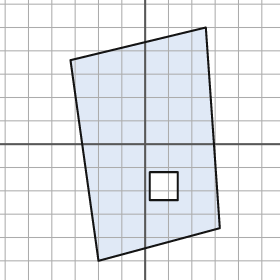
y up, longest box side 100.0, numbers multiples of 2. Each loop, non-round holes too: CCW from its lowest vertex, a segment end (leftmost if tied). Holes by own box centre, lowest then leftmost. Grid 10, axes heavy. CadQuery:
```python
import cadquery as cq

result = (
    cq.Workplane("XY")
    .moveTo(-20.0, -50.0)
    .lineTo(32.0, -36.0)
    .lineTo(26.0, 50.0)
    .lineTo(-32.0, 36.0)
    .close()
    .moveTo(2.0, -24.0)
    .lineTo(14.0, -24.0)
    .lineTo(14.0, -12.0)
    .lineTo(2.0, -12.0)
    .close()
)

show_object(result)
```